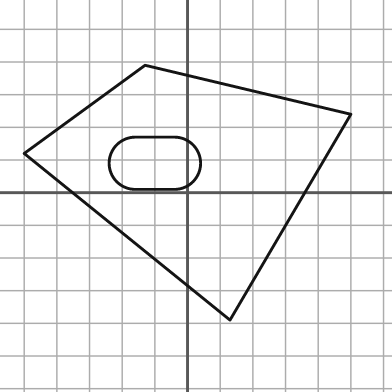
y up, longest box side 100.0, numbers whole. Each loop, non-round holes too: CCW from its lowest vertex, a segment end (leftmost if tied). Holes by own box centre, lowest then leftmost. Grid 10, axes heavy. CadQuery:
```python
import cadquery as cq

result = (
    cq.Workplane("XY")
    .moveTo(13.0, -39.0)
    .lineTo(50.0, 24.0)
    .lineTo(-13.0, 39.0)
    .lineTo(-50.0, 12.0)
    .close()
    .moveTo(-16.0, 1.0)
    .lineTo(-4.0, 1.0)
    .threePointArc((4.0, 9.0), (-4.0, 17.0))
    .lineTo(-16.0, 17.0)
    .threePointArc((-24.0, 9.0), (-16.0, 1.0))
    .close()
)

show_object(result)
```